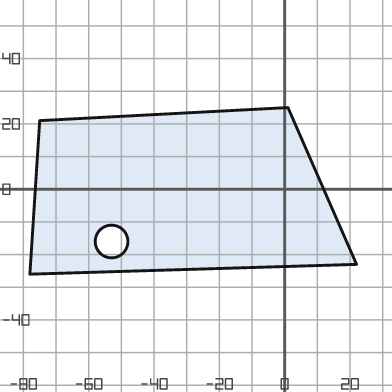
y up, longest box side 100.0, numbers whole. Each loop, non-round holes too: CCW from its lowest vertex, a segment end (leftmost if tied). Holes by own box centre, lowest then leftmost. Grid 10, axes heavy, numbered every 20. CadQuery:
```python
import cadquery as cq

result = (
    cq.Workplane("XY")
    .moveTo(-78.0, -26.0)
    .lineTo(22.0, -23.0)
    .lineTo(1.0, 25.0)
    .lineTo(-75.0, 21.0)
    .close()
    .moveTo(-53.0, -16.0)
    .circle(5.0)
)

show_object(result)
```